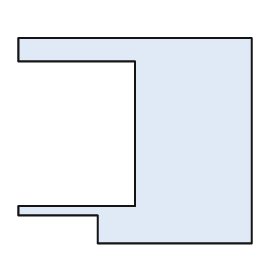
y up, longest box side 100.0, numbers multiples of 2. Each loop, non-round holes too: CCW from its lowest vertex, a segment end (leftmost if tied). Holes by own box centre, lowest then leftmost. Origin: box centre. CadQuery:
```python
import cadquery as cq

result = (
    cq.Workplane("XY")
    .moveTo(-16.0, -44.0)
    .lineTo(50.0, -44.0)
    .lineTo(50.0, 44.0)
    .lineTo(-50.0, 44.0)
    .lineTo(-50.0, 34.0)
    .lineTo(0.0, 34.0)
    .lineTo(0.0, -28.0)
    .lineTo(-50.0, -28.0)
    .lineTo(-50.0, -32.0)
    .lineTo(-16.0, -32.0)
    .close()
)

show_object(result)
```